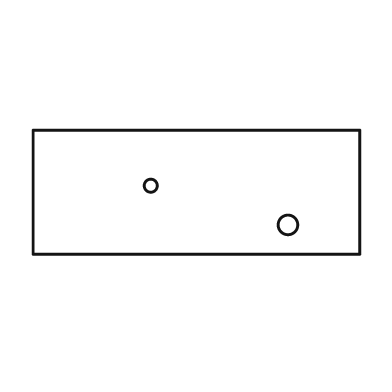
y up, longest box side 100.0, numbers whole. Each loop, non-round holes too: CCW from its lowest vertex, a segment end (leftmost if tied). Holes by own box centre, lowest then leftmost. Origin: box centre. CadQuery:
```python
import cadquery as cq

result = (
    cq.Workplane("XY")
    .moveTo(-50.0, -19.0)
    .lineTo(50.0, -19.0)
    .lineTo(50.0, 19.0)
    .lineTo(-50.0, 19.0)
    .close()
    .moveTo(28.0, -10.0)
    .circle(3.0)
    .moveTo(-14.0, 2.0)
    .circle(2.0)
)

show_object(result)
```